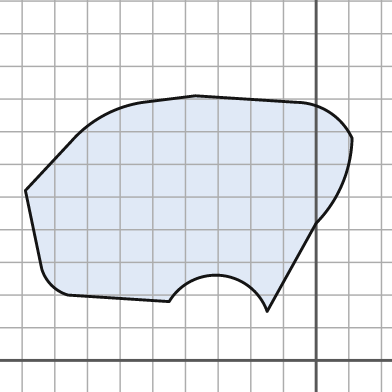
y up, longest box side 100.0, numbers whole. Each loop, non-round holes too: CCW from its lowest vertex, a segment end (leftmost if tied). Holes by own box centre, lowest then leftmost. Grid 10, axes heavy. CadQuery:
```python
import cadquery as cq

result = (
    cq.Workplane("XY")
    .moveTo(-15.0, 15.0)
    .lineTo(0.0, 42.0)
    .threePointArc((8.0, 54.0), (11.0, 68.0))
    .threePointArc((4.0, 76.0), (-6.0, 79.0))
    .lineTo(-37.0, 81.0)
    .lineTo(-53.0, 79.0)
    .threePointArc((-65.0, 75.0), (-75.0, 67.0))
    .lineTo(-89.0, 52.0)
    .lineTo(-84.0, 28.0)
    .threePointArc((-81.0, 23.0), (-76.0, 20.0))
    .lineTo(-45.0, 18.0)
    .threePointArc((-29.0, 26.0), (-15.0, 15.0))
    .close()
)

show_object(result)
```